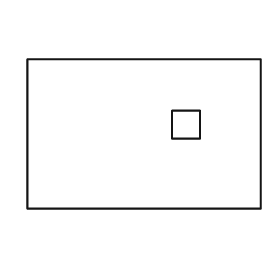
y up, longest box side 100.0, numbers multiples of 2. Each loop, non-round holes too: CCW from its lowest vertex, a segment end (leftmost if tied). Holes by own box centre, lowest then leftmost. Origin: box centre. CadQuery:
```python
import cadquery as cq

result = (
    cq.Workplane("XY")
    .moveTo(-50.0, -32.0)
    .lineTo(50.0, -32.0)
    .lineTo(50.0, 32.0)
    .lineTo(-50.0, 32.0)
    .close()
    .moveTo(12.0, -2.0)
    .lineTo(24.0, -2.0)
    .lineTo(24.0, 10.0)
    .lineTo(12.0, 10.0)
    .close()
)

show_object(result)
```